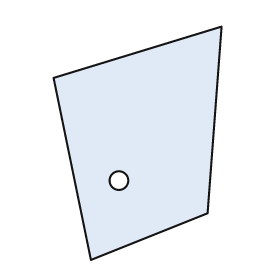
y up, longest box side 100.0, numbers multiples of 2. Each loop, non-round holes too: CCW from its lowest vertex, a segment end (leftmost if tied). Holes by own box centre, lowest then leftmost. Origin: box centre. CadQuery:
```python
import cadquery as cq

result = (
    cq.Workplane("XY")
    .moveTo(-20.0, -50.0)
    .lineTo(30.0, -30.0)
    .lineTo(36.0, 50.0)
    .lineTo(-36.0, 28.0)
    .close()
    .moveTo(-8.0, -16.0)
    .circle(4.0)
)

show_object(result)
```